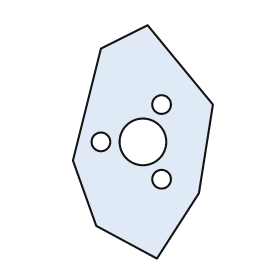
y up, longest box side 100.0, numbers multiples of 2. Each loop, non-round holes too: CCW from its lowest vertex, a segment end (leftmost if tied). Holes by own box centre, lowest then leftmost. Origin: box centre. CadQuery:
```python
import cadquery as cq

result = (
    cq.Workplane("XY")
    .moveTo(6.0, -50.0)
    .lineTo(24.0, -22.0)
    .lineTo(30.0, 16.0)
    .lineTo(2.0, 50.0)
    .lineTo(-18.0, 40.0)
    .lineTo(-30.0, -8.0)
    .lineTo(-20.0, -36.0)
    .close()
    .moveTo(8.0, -16.0)
    .circle(4.0)
    .moveTo(-18.0, 0.0)
    .circle(4.0)
    .moveTo(0.0, 0.0)
    .circle(10.0)
    .moveTo(8.0, 16.0)
    .circle(4.0)
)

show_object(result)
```